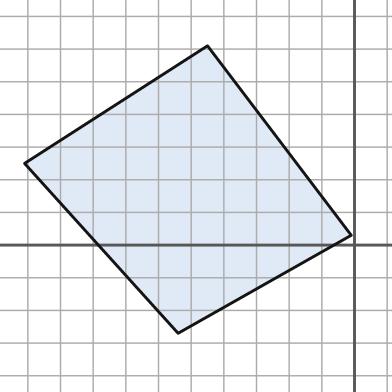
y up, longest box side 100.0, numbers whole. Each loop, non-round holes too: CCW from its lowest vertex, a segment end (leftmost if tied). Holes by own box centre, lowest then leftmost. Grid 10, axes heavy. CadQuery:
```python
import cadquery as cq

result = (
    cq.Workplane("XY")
    .moveTo(-54.0, -27.0)
    .lineTo(-1.0, 3.0)
    .lineTo(-45.0, 61.0)
    .lineTo(-101.0, 25.0)
    .close()
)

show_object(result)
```